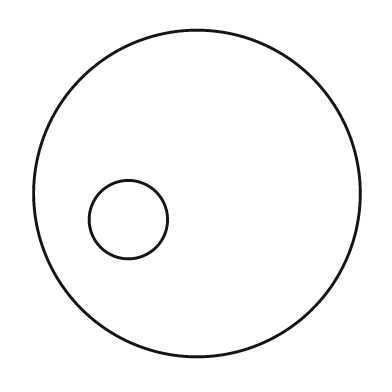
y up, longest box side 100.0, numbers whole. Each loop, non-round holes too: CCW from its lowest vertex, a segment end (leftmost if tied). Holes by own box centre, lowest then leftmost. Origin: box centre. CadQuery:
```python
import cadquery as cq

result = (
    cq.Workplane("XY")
    .moveTo(0.0, 0.0)
    .circle(50.0)
    .moveTo(-21.0, -8.0)
    .circle(12.0)
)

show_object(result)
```